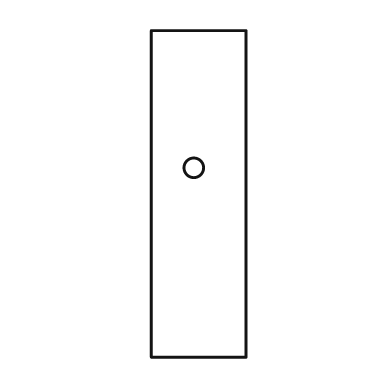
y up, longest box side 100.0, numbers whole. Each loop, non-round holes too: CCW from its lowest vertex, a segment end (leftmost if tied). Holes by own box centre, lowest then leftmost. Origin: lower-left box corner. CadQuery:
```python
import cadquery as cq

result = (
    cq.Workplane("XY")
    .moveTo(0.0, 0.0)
    .lineTo(29.0, 0.0)
    .lineTo(29.0, 100.0)
    .lineTo(0.0, 100.0)
    .close()
    .moveTo(13.0, 58.0)
    .circle(3.0)
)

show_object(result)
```